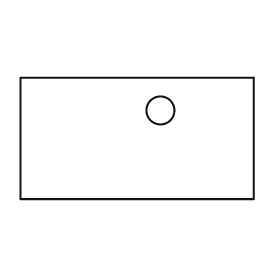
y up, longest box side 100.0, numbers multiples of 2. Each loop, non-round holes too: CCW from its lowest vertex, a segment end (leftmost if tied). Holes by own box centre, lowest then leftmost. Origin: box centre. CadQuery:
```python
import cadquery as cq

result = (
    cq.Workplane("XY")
    .moveTo(-50.0, -26.0)
    .lineTo(50.0, -26.0)
    .lineTo(50.0, 26.0)
    .lineTo(-50.0, 26.0)
    .close()
    .moveTo(10.0, 12.0)
    .circle(6.0)
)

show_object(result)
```